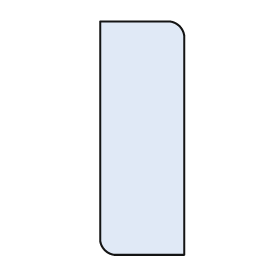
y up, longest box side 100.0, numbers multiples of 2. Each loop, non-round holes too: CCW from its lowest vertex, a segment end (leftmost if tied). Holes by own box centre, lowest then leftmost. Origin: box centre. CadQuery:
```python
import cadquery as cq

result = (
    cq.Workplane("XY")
    .moveTo(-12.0, -50.0)
    .lineTo(18.0, -50.0)
    .lineTo(18.0, 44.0)
    .threePointArc((16.0, 48.0), (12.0, 50.0))
    .lineTo(-18.0, 50.0)
    .lineTo(-18.0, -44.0)
    .threePointArc((-16.0, -48.0), (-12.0, -50.0))
    .close()
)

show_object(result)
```